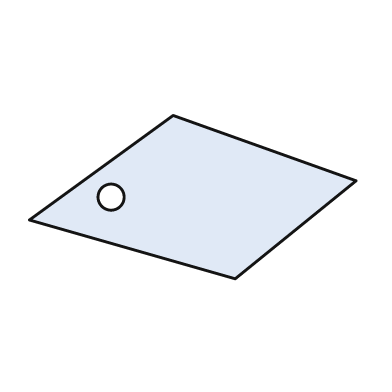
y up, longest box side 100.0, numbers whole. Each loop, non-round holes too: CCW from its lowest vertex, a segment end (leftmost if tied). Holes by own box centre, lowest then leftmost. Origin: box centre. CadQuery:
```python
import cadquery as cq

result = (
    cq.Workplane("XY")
    .moveTo(13.0, -25.0)
    .lineTo(50.0, 5.0)
    .lineTo(-6.0, 25.0)
    .lineTo(-50.0, -7.0)
    .close()
    .moveTo(-25.0, 0.0)
    .circle(4.0)
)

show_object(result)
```